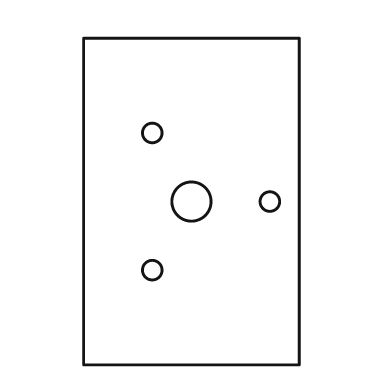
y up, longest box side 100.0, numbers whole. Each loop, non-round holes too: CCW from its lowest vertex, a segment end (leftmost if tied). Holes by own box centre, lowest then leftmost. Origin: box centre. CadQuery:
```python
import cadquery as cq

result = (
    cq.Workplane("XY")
    .moveTo(-33.0, -50.0)
    .lineTo(33.0, -50.0)
    .lineTo(33.0, 50.0)
    .lineTo(-33.0, 50.0)
    .close()
    .moveTo(-12.0, -21.0)
    .circle(3.0)
    .moveTo(0.0, 0.0)
    .circle(6.0)
    .moveTo(24.0, 0.0)
    .circle(3.0)
    .moveTo(-12.0, 21.0)
    .circle(3.0)
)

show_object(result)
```